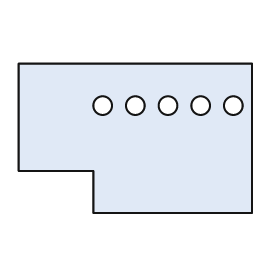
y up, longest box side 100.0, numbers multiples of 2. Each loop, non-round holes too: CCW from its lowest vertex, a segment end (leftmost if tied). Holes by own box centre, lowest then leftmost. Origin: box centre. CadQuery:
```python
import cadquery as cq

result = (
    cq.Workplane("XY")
    .moveTo(-18.0, -32.0)
    .lineTo(50.0, -32.0)
    .lineTo(50.0, 32.0)
    .lineTo(-50.0, 32.0)
    .lineTo(-50.0, -14.0)
    .lineTo(-18.0, -14.0)
    .close()
    .moveTo(-14.0, 14.0)
    .circle(4.0)
    .moveTo(0.0, 14.0)
    .circle(4.0)
    .moveTo(14.0, 14.0)
    .circle(4.0)
    .moveTo(28.0, 14.0)
    .circle(4.0)
    .moveTo(42.0, 14.0)
    .circle(4.0)
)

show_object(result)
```